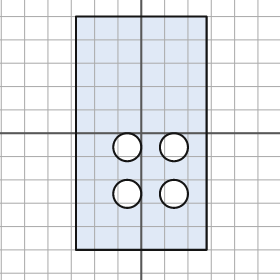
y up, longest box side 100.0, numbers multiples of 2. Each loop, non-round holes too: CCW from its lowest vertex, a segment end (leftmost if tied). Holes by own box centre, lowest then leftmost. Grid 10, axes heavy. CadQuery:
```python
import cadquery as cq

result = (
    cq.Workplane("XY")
    .moveTo(-28.0, -50.0)
    .lineTo(28.0, -50.0)
    .lineTo(28.0, 50.0)
    .lineTo(-28.0, 50.0)
    .close()
    .moveTo(-6.0, -26.0)
    .circle(6.0)
    .moveTo(14.0, -26.0)
    .circle(6.0)
    .moveTo(-6.0, -6.0)
    .circle(6.0)
    .moveTo(14.0, -6.0)
    .circle(6.0)
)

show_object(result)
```